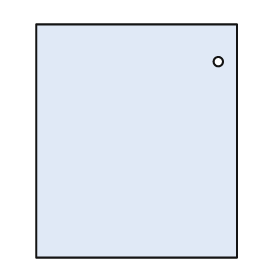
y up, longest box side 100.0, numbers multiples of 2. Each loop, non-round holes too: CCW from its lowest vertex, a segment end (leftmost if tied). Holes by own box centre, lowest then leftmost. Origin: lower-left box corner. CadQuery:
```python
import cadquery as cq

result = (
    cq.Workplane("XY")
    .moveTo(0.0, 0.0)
    .lineTo(86.0, 0.0)
    .lineTo(86.0, 100.0)
    .lineTo(0.0, 100.0)
    .close()
    .moveTo(78.0, 84.0)
    .circle(2.0)
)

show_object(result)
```